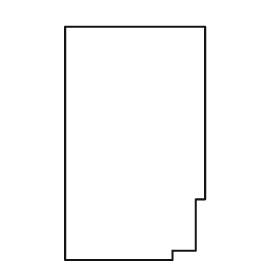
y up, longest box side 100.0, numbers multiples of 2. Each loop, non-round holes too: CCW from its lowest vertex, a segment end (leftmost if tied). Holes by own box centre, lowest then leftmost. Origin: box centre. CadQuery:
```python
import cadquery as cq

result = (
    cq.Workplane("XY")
    .moveTo(-30.0, -50.0)
    .lineTo(16.0, -50.0)
    .lineTo(16.0, -46.0)
    .lineTo(26.0, -46.0)
    .lineTo(26.0, -24.0)
    .lineTo(30.0, -24.0)
    .lineTo(30.0, 50.0)
    .lineTo(-30.0, 50.0)
    .close()
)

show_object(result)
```